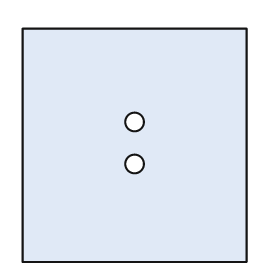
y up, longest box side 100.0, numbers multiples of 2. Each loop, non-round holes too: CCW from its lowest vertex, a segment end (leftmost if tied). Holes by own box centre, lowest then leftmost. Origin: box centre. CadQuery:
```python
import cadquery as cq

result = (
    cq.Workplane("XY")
    .moveTo(-48.0, -50.0)
    .lineTo(48.0, -50.0)
    .lineTo(48.0, 50.0)
    .lineTo(-48.0, 50.0)
    .close()
    .moveTo(0.0, -8.0)
    .circle(4.0)
    .moveTo(0.0, 10.0)
    .circle(4.0)
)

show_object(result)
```